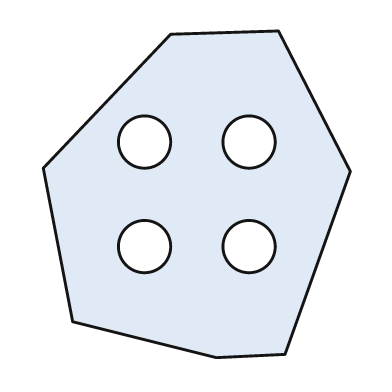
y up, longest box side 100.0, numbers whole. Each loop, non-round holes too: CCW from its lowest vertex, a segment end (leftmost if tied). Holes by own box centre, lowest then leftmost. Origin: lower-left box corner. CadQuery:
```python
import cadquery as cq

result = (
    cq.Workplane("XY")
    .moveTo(53.0, 0.0)
    .lineTo(74.0, 1.0)
    .lineTo(94.0, 57.0)
    .lineTo(72.0, 100.0)
    .lineTo(39.0, 99.0)
    .lineTo(0.0, 58.0)
    .lineTo(9.0, 11.0)
    .close()
    .moveTo(31.0, 34.0)
    .circle(8.0)
    .moveTo(63.0, 34.0)
    .circle(8.0)
    .moveTo(31.0, 66.0)
    .circle(8.0)
    .moveTo(63.0, 66.0)
    .circle(8.0)
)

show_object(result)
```